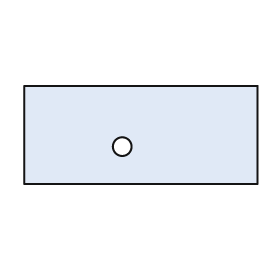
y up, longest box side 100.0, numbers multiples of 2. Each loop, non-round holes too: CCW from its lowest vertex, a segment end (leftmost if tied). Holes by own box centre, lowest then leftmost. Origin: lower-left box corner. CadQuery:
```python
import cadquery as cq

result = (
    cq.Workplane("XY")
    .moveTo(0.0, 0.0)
    .lineTo(100.0, 0.0)
    .lineTo(100.0, 42.0)
    .lineTo(0.0, 42.0)
    .close()
    .moveTo(42.0, 16.0)
    .circle(4.0)
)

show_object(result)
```